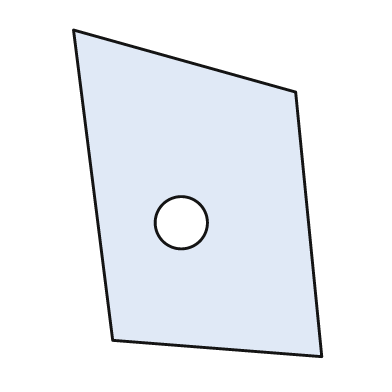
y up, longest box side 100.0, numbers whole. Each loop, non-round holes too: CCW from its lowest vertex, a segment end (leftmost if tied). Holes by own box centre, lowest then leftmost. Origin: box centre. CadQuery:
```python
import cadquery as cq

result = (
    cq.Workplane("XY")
    .moveTo(38.0, -50.0)
    .lineTo(30.0, 31.0)
    .lineTo(-38.0, 50.0)
    .lineTo(-26.0, -45.0)
    .close()
    .moveTo(-5.0, -9.0)
    .circle(8.0)
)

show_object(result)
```